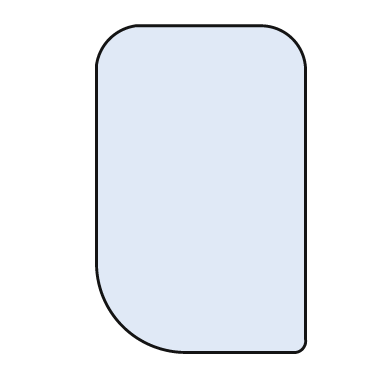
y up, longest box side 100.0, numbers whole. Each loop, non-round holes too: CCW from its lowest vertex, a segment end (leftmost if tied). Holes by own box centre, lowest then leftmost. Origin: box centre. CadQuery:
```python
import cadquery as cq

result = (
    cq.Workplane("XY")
    .moveTo(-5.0, -50.0)
    .lineTo(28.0, -50.0)
    .threePointArc((31.0, -49.0), (32.0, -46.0))
    .lineTo(32.0, 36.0)
    .threePointArc((28.0, 46.0), (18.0, 50.0))
    .lineTo(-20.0, 50.0)
    .threePointArc((-28.0, 46.0), (-32.0, 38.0))
    .lineTo(-32.0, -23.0)
    .threePointArc((-24.0, -42.0), (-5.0, -50.0))
    .close()
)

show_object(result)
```